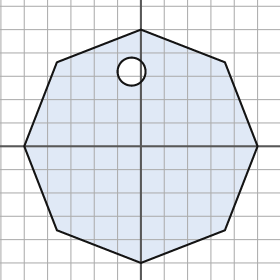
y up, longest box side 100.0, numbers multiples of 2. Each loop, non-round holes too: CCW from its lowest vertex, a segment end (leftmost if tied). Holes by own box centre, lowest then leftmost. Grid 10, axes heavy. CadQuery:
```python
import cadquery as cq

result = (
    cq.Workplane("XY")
    .moveTo(0.0, -50.0)
    .lineTo(36.0, -36.0)
    .lineTo(50.0, 0.0)
    .lineTo(36.0, 36.0)
    .lineTo(0.0, 50.0)
    .lineTo(-36.0, 36.0)
    .lineTo(-50.0, 0.0)
    .lineTo(-36.0, -36.0)
    .close()
    .moveTo(-4.0, 32.0)
    .circle(6.0)
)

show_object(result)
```